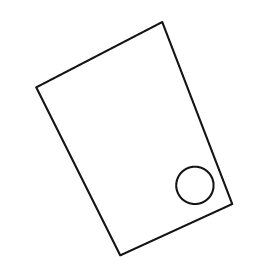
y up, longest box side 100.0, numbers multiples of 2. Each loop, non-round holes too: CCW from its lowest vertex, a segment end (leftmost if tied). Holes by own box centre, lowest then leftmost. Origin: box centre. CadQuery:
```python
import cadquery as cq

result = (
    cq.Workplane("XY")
    .moveTo(-6.0, -50.0)
    .lineTo(42.0, -28.0)
    .lineTo(12.0, 50.0)
    .lineTo(-42.0, 22.0)
    .close()
    .moveTo(26.0, -20.0)
    .circle(8.0)
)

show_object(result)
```